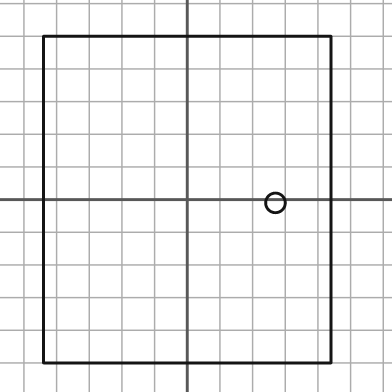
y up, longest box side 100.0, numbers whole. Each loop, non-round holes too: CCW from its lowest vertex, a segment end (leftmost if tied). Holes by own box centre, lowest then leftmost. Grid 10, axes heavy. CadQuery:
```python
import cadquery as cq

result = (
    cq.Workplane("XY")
    .moveTo(-44.0, -50.0)
    .lineTo(44.0, -50.0)
    .lineTo(44.0, 50.0)
    .lineTo(-44.0, 50.0)
    .close()
    .moveTo(27.0, -1.0)
    .circle(3.0)
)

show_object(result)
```